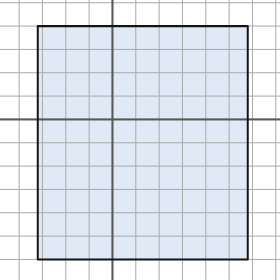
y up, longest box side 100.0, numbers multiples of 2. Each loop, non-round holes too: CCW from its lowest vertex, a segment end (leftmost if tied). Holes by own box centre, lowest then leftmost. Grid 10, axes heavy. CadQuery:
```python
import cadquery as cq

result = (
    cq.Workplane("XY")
    .moveTo(-32.0, -60.0)
    .lineTo(58.0, -60.0)
    .lineTo(58.0, 40.0)
    .lineTo(-32.0, 40.0)
    .close()
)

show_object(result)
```